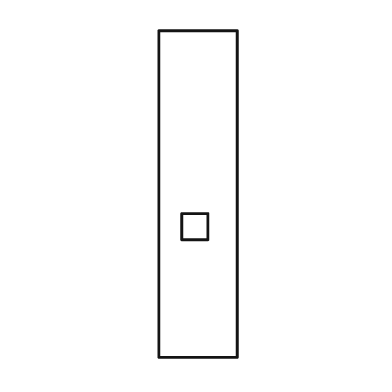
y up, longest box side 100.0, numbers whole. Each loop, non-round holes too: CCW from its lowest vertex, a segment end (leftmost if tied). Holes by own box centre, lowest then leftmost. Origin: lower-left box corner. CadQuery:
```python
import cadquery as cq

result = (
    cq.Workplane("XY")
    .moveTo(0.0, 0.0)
    .lineTo(24.0, 0.0)
    .lineTo(24.0, 100.0)
    .lineTo(0.0, 100.0)
    .close()
    .moveTo(7.0, 36.0)
    .lineTo(15.0, 36.0)
    .lineTo(15.0, 44.0)
    .lineTo(7.0, 44.0)
    .close()
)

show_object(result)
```